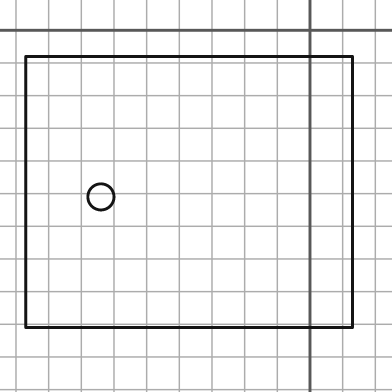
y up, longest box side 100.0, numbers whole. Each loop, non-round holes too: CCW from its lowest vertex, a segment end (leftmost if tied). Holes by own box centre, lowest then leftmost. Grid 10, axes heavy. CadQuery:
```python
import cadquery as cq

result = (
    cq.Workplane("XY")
    .moveTo(-87.0, -91.0)
    .lineTo(13.0, -91.0)
    .lineTo(13.0, -8.0)
    .lineTo(-87.0, -8.0)
    .close()
    .moveTo(-64.0, -51.0)
    .circle(4.0)
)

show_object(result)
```